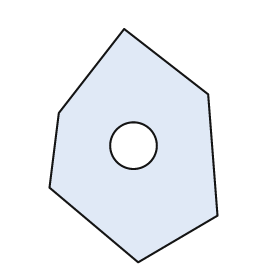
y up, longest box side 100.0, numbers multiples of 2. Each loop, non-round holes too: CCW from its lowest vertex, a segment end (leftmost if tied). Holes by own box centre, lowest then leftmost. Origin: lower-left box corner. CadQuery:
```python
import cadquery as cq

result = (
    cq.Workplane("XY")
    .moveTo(38.0, 0.0)
    .lineTo(72.0, 20.0)
    .lineTo(68.0, 72.0)
    .lineTo(32.0, 100.0)
    .lineTo(4.0, 64.0)
    .lineTo(0.0, 32.0)
    .close()
    .moveTo(36.0, 50.0)
    .circle(10.0)
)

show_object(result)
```